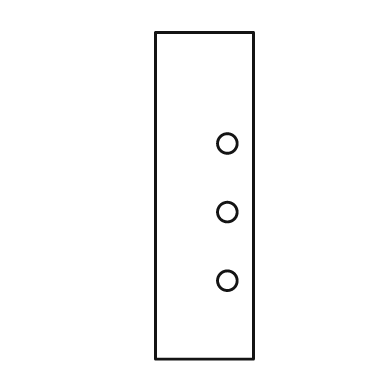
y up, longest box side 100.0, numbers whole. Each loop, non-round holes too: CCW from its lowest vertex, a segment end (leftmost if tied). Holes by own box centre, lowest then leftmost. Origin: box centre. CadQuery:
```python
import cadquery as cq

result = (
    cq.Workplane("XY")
    .moveTo(-15.0, -50.0)
    .lineTo(15.0, -50.0)
    .lineTo(15.0, 50.0)
    .lineTo(-15.0, 50.0)
    .close()
    .moveTo(7.0, -26.0)
    .circle(3.0)
    .moveTo(7.0, -5.0)
    .circle(3.0)
    .moveTo(7.0, 16.0)
    .circle(3.0)
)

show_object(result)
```